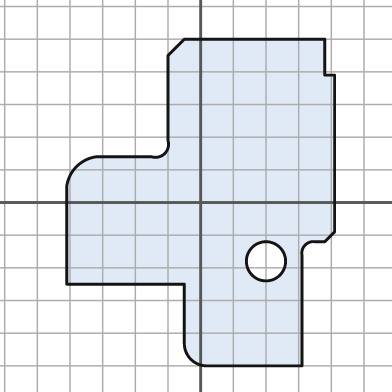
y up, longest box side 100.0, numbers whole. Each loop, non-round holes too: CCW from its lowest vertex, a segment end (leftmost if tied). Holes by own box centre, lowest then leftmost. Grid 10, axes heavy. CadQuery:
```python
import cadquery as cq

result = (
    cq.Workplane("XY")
    .moveTo(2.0, -50.0)
    .lineTo(31.0, -50.0)
    .lineTo(31.0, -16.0)
    .threePointArc((32.0, -13.0), (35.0, -12.0))
    .lineTo(38.0, -12.0)
    .lineTo(41.0, -9.0)
    .lineTo(41.0, 39.0)
    .lineTo(38.0, 39.0)
    .lineTo(38.0, 50.0)
    .lineTo(-5.0, 50.0)
    .lineTo(-10.0, 45.0)
    .lineTo(-10.0, 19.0)
    .threePointArc((-11.0, 15.0), (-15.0, 14.0))
    .lineTo(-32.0, 14.0)
    .threePointArc((-38.0, 11.0), (-41.0, 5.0))
    .lineTo(-41.0, -25.0)
    .lineTo(-5.0, -25.0)
    .lineTo(-5.0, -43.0)
    .threePointArc((-3.0, -48.0), (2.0, -50.0))
    .close()
    .moveTo(20.0, -18.0)
    .circle(6.0)
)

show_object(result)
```